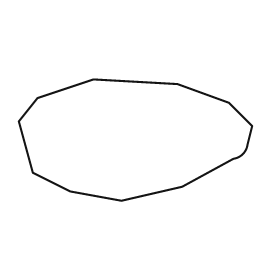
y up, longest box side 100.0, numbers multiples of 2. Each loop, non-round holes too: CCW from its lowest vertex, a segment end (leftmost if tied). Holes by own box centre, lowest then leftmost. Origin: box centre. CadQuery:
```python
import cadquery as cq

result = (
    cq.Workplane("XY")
    .moveTo(-6.0, -26.0)
    .lineTo(20.0, -20.0)
    .lineTo(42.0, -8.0)
    .threePointArc((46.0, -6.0), (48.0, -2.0))
    .lineTo(50.0, 6.0)
    .lineTo(40.0, 16.0)
    .lineTo(18.0, 24.0)
    .lineTo(-18.0, 26.0)
    .lineTo(-42.0, 18.0)
    .lineTo(-50.0, 8.0)
    .lineTo(-44.0, -14.0)
    .lineTo(-28.0, -22.0)
    .close()
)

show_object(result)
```